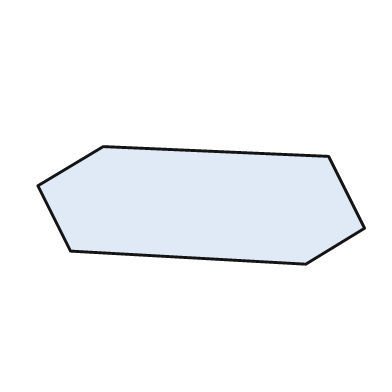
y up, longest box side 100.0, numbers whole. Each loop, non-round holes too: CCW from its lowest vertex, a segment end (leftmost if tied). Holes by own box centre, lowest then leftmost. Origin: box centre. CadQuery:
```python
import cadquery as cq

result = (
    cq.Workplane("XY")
    .moveTo(32.0, -18.0)
    .lineTo(50.0, -7.0)
    .lineTo(39.0, 15.0)
    .lineTo(-30.0, 18.0)
    .lineTo(-50.0, 6.0)
    .lineTo(-40.0, -14.0)
    .close()
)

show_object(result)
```